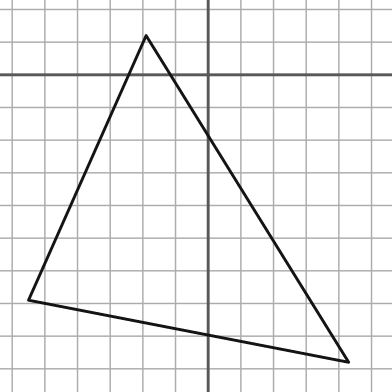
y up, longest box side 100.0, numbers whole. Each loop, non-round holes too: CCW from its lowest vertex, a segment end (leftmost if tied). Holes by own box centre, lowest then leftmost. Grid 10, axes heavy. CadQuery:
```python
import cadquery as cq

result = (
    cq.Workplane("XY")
    .moveTo(43.0, -88.0)
    .lineTo(-19.0, 12.0)
    .lineTo(-55.0, -69.0)
    .close()
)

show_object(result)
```